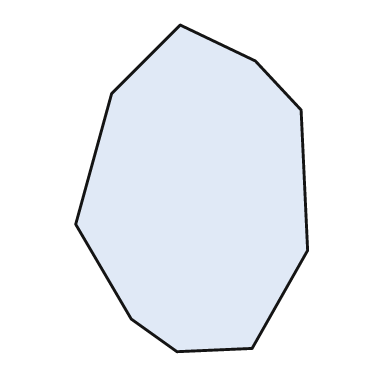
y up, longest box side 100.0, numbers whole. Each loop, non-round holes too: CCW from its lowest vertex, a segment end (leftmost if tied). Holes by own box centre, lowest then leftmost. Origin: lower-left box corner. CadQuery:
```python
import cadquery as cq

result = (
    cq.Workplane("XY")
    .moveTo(31.0, 0.0)
    .lineTo(54.0, 1.0)
    .lineTo(71.0, 31.0)
    .lineTo(69.0, 74.0)
    .lineTo(55.0, 89.0)
    .lineTo(32.0, 100.0)
    .lineTo(11.0, 79.0)
    .lineTo(0.0, 39.0)
    .lineTo(17.0, 10.0)
    .close()
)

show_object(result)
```